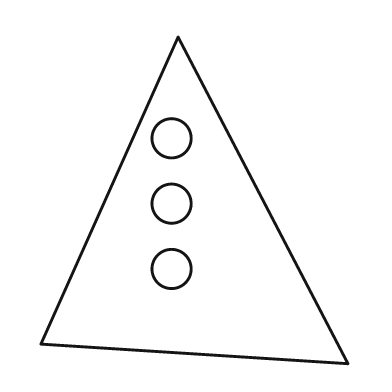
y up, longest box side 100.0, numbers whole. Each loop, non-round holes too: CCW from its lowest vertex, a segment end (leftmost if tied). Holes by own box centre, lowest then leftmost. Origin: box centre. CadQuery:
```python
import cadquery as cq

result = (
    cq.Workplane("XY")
    .moveTo(47.0, -50.0)
    .lineTo(-5.0, 50.0)
    .lineTo(-47.0, -44.0)
    .close()
    .moveTo(-7.0, -21.0)
    .circle(6.0)
    .moveTo(-7.0, -1.0)
    .circle(6.0)
    .moveTo(-7.0, 19.0)
    .circle(6.0)
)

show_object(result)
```